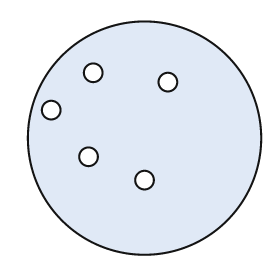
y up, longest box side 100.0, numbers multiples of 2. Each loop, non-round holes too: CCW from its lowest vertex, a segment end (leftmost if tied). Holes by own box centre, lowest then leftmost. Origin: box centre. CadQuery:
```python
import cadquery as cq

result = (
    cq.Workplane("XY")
    .moveTo(0.0, 0.0)
    .circle(50.0)
    .moveTo(0.0, -18.0)
    .circle(4.0)
    .moveTo(-24.0, -8.0)
    .circle(4.0)
    .moveTo(-40.0, 12.0)
    .circle(4.0)
    .moveTo(10.0, 24.0)
    .circle(4.0)
    .moveTo(-22.0, 28.0)
    .circle(4.0)
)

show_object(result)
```